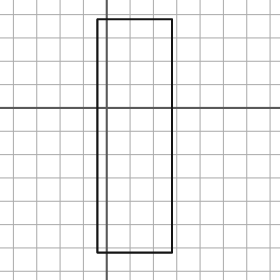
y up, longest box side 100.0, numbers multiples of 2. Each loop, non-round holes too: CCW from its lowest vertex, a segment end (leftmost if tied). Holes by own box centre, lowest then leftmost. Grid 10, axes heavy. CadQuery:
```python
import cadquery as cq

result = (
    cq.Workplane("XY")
    .moveTo(-4.0, -62.0)
    .lineTo(28.0, -62.0)
    .lineTo(28.0, 38.0)
    .lineTo(-4.0, 38.0)
    .close()
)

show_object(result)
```